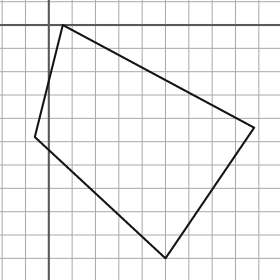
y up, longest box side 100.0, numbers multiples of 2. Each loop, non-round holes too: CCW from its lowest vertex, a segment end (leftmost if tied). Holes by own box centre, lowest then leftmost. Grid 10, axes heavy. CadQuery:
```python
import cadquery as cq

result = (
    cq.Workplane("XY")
    .moveTo(50.0, -100.0)
    .lineTo(88.0, -44.0)
    .lineTo(6.0, 0.0)
    .lineTo(-6.0, -48.0)
    .close()
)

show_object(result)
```